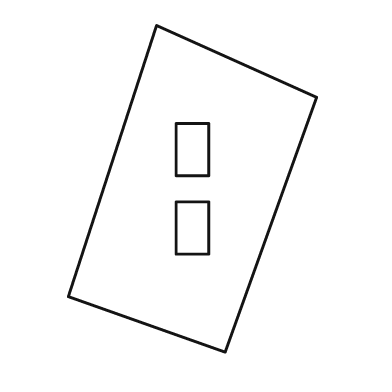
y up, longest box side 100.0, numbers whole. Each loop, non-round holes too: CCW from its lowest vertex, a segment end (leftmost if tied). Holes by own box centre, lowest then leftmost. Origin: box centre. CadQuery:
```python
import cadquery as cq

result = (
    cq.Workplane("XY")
    .moveTo(10.0, -50.0)
    .lineTo(38.0, 28.0)
    .lineTo(-11.0, 50.0)
    .lineTo(-38.0, -33.0)
    .close()
    .moveTo(-5.0, -20.0)
    .lineTo(5.0, -20.0)
    .lineTo(5.0, -4.0)
    .lineTo(-5.0, -4.0)
    .close()
    .moveTo(-5.0, 4.0)
    .lineTo(5.0, 4.0)
    .lineTo(5.0, 20.0)
    .lineTo(-5.0, 20.0)
    .close()
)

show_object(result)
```